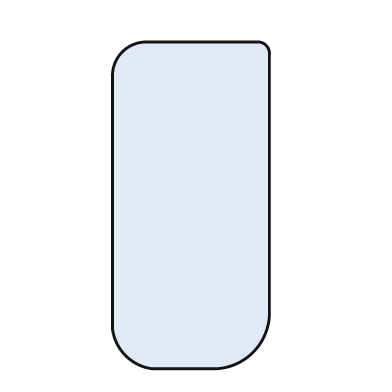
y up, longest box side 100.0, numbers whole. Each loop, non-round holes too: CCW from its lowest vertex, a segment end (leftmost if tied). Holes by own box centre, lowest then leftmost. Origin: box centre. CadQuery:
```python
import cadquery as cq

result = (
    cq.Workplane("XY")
    .moveTo(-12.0, -50.0)
    .lineTo(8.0, -50.0)
    .threePointArc((19.0, -45.0), (24.0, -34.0))
    .lineTo(24.0, 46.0)
    .threePointArc((23.0, 49.0), (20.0, 50.0))
    .lineTo(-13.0, 50.0)
    .threePointArc((-21.0, 47.0), (-24.0, 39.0))
    .lineTo(-24.0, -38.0)
    .threePointArc((-20.0, -46.0), (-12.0, -50.0))
    .close()
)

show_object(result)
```